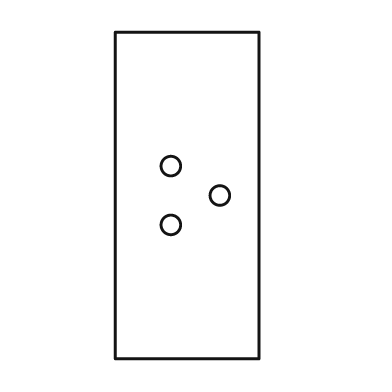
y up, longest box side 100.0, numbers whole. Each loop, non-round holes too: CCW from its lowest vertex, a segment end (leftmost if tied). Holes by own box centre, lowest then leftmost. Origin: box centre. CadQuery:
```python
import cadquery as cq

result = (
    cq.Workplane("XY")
    .moveTo(-22.0, -50.0)
    .lineTo(22.0, -50.0)
    .lineTo(22.0, 50.0)
    .lineTo(-22.0, 50.0)
    .close()
    .moveTo(-5.0, -9.0)
    .circle(3.0)
    .moveTo(10.0, 0.0)
    .circle(3.0)
    .moveTo(-5.0, 9.0)
    .circle(3.0)
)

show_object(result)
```